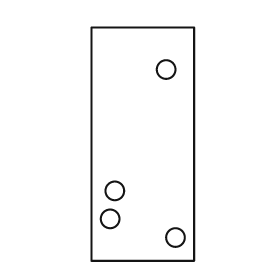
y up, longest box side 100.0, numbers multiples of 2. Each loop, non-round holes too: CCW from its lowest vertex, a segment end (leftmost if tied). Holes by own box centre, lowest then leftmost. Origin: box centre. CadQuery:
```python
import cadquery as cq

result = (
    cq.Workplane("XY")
    .moveTo(-22.0, -50.0)
    .lineTo(22.0, -50.0)
    .lineTo(22.0, 50.0)
    .lineTo(-22.0, 50.0)
    .close()
    .moveTo(14.0, -40.0)
    .circle(4.0)
    .moveTo(-14.0, -32.0)
    .circle(4.0)
    .moveTo(-12.0, -20.0)
    .circle(4.0)
    .moveTo(10.0, 32.0)
    .circle(4.0)
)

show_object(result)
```